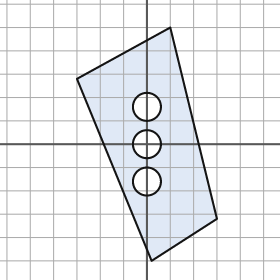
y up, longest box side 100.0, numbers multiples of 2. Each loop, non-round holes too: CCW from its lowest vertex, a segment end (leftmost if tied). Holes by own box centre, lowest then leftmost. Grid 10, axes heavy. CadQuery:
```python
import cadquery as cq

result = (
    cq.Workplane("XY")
    .moveTo(2.0, -50.0)
    .lineTo(30.0, -32.0)
    .lineTo(10.0, 50.0)
    .lineTo(-30.0, 28.0)
    .close()
    .moveTo(0.0, -16.0)
    .circle(6.0)
    .moveTo(0.0, 0.0)
    .circle(6.0)
    .moveTo(0.0, 16.0)
    .circle(6.0)
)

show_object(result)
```